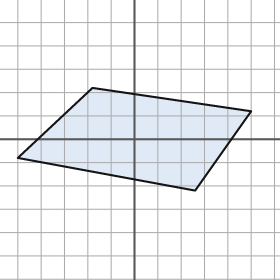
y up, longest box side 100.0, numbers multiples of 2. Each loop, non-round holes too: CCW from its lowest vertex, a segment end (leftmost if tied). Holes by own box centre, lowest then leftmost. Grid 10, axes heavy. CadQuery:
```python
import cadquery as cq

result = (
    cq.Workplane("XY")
    .moveTo(26.0, -22.0)
    .lineTo(50.0, 12.0)
    .lineTo(-18.0, 22.0)
    .lineTo(-50.0, -8.0)
    .close()
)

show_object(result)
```